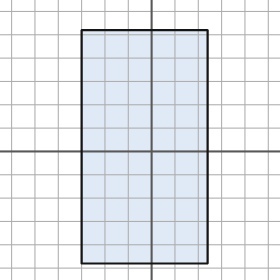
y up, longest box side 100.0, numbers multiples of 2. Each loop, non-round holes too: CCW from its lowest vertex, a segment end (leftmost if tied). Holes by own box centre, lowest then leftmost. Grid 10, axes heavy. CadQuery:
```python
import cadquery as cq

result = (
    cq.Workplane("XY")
    .moveTo(-30.0, -48.0)
    .lineTo(24.0, -48.0)
    .lineTo(24.0, 52.0)
    .lineTo(-30.0, 52.0)
    .close()
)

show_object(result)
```